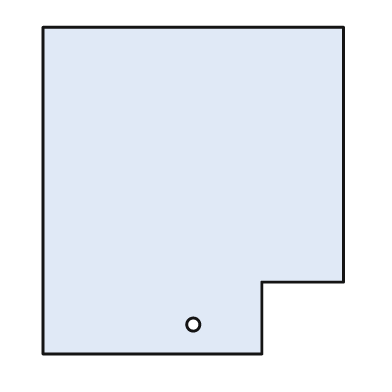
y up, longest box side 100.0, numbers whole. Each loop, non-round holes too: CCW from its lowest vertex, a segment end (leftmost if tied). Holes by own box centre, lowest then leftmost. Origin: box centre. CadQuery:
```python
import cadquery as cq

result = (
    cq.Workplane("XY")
    .moveTo(-46.0, -50.0)
    .lineTo(21.0, -50.0)
    .lineTo(21.0, -28.0)
    .lineTo(46.0, -28.0)
    .lineTo(46.0, 50.0)
    .lineTo(-46.0, 50.0)
    .close()
    .moveTo(0.0, -41.0)
    .circle(2.0)
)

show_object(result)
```